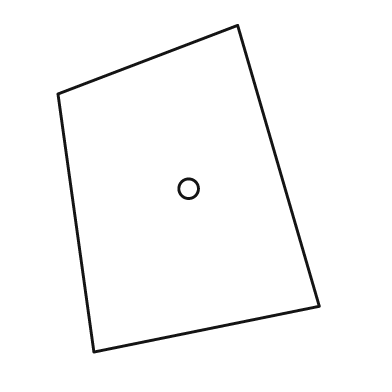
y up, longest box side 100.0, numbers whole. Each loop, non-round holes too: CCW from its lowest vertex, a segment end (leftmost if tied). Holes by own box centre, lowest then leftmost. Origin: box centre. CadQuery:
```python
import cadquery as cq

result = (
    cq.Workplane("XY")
    .moveTo(-29.0, -50.0)
    .lineTo(40.0, -36.0)
    .lineTo(15.0, 50.0)
    .lineTo(-40.0, 29.0)
    .close()
    .moveTo(0.0, 0.0)
    .circle(3.0)
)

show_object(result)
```